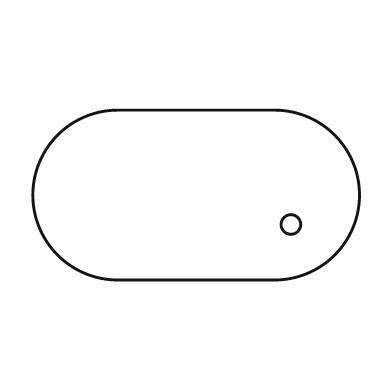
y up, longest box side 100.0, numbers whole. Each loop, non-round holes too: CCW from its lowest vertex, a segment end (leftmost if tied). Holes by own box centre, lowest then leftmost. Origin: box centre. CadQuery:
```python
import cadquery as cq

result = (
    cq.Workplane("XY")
    .moveTo(-24.0, -26.0)
    .lineTo(24.0, -26.0)
    .threePointArc((50.0, 0.0), (24.0, 26.0))
    .lineTo(-24.0, 26.0)
    .threePointArc((-50.0, 0.0), (-24.0, -26.0))
    .close()
    .moveTo(29.0, -9.0)
    .circle(3.0)
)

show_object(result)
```